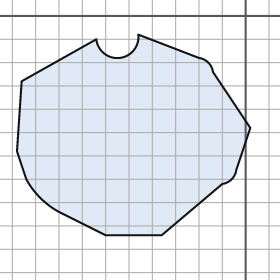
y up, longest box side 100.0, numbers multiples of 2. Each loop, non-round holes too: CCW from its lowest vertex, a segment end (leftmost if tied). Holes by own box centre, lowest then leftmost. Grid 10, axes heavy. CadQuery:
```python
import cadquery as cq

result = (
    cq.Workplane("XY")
    .moveTo(-60.0, -94.0)
    .lineTo(-36.0, -94.0)
    .lineTo(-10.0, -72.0)
    .threePointArc((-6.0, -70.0), (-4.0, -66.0))
    .lineTo(2.0, -48.0)
    .lineTo(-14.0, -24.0)
    .threePointArc((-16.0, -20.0), (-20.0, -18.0))
    .lineTo(-46.0, -8.0)
    .threePointArc((-54.0, -18.0), (-64.0, -10.0))
    .lineTo(-96.0, -28.0)
    .lineTo(-98.0, -58.0)
    .lineTo(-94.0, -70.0)
    .threePointArc((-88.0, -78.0), (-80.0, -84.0))
    .close()
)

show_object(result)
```